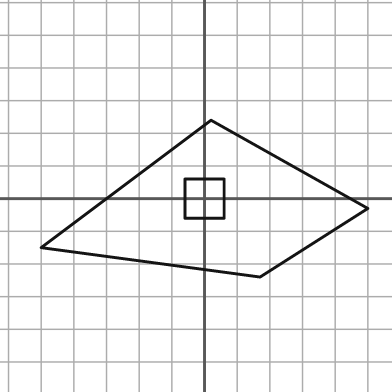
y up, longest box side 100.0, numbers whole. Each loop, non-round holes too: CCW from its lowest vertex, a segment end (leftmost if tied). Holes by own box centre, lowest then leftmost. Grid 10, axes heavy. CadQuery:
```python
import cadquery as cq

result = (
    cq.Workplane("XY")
    .moveTo(17.0, -24.0)
    .lineTo(50.0, -3.0)
    .lineTo(2.0, 24.0)
    .lineTo(-50.0, -15.0)
    .close()
    .moveTo(-6.0, -6.0)
    .lineTo(6.0, -6.0)
    .lineTo(6.0, 6.0)
    .lineTo(-6.0, 6.0)
    .close()
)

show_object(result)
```